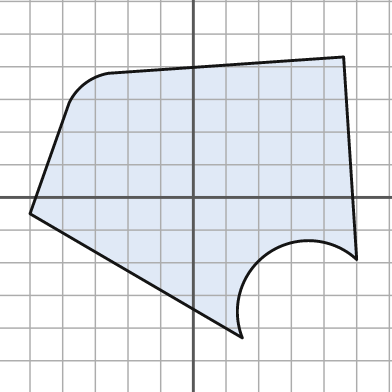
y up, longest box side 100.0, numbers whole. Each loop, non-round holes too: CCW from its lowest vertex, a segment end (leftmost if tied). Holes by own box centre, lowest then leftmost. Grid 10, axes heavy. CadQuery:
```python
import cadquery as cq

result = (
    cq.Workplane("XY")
    .moveTo(15.0, -43.0)
    .threePointArc((23.0, -17.0), (50.0, -19.0))
    .lineTo(46.0, 43.0)
    .lineTo(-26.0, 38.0)
    .threePointArc((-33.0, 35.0), (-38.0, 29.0))
    .lineTo(-50.0, -5.0)
    .close()
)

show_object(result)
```